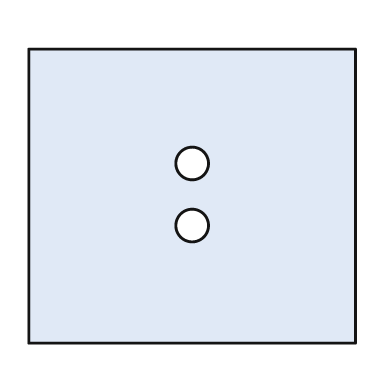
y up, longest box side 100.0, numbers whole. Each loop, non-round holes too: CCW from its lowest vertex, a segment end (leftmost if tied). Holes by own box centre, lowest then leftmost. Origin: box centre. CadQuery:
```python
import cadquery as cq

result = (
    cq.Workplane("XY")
    .moveTo(-50.0, -45.0)
    .lineTo(50.0, -45.0)
    .lineTo(50.0, 45.0)
    .lineTo(-50.0, 45.0)
    .close()
    .moveTo(0.0, -9.0)
    .circle(5.0)
    .moveTo(0.0, 10.0)
    .circle(5.0)
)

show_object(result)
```